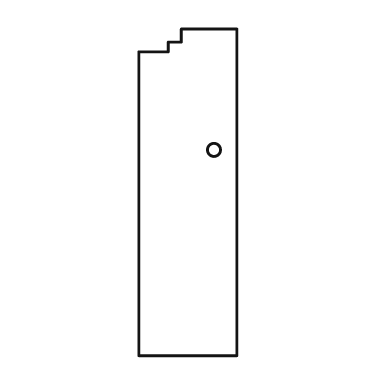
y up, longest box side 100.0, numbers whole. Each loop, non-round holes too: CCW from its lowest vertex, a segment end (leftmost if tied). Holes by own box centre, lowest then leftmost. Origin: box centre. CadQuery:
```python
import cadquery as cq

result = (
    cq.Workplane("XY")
    .moveTo(-15.0, -50.0)
    .lineTo(15.0, -50.0)
    .lineTo(15.0, 50.0)
    .lineTo(-2.0, 50.0)
    .lineTo(-2.0, 46.0)
    .lineTo(-6.0, 46.0)
    .lineTo(-6.0, 43.0)
    .lineTo(-15.0, 43.0)
    .close()
    .moveTo(8.0, 13.0)
    .circle(2.0)
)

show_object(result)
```